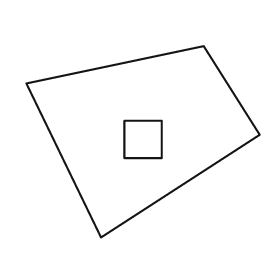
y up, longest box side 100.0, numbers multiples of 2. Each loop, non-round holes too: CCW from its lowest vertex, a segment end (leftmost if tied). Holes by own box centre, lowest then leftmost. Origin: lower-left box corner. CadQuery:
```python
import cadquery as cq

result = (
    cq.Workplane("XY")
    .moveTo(32.0, 0.0)
    .lineTo(100.0, 44.0)
    .lineTo(76.0, 82.0)
    .lineTo(0.0, 66.0)
    .close()
    .moveTo(42.0, 34.0)
    .lineTo(58.0, 34.0)
    .lineTo(58.0, 50.0)
    .lineTo(42.0, 50.0)
    .close()
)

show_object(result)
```